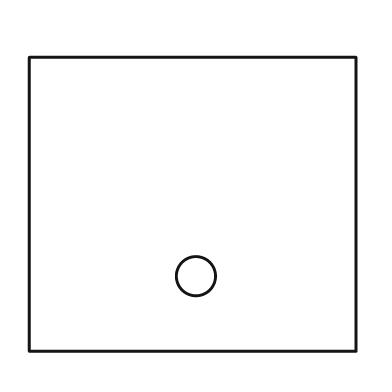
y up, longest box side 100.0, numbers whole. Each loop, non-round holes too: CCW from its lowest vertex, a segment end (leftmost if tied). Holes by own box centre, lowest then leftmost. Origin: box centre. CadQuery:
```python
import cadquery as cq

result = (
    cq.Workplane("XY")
    .moveTo(-50.0, -45.0)
    .lineTo(50.0, -45.0)
    .lineTo(50.0, 45.0)
    .lineTo(-50.0, 45.0)
    .close()
    .moveTo(1.0, -22.0)
    .circle(6.0)
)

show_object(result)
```